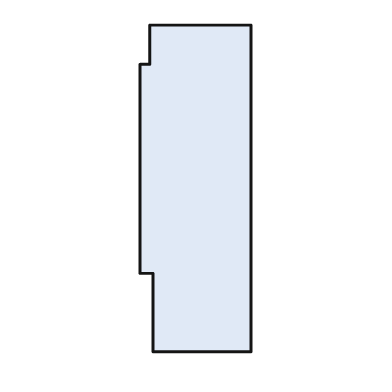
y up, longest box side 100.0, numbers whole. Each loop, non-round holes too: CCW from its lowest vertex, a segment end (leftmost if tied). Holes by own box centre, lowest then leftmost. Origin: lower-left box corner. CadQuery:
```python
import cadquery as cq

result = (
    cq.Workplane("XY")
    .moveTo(4.0, 0.0)
    .lineTo(34.0, 0.0)
    .lineTo(34.0, 100.0)
    .lineTo(3.0, 100.0)
    .lineTo(3.0, 88.0)
    .lineTo(0.0, 88.0)
    .lineTo(0.0, 24.0)
    .lineTo(4.0, 24.0)
    .close()
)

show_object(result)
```